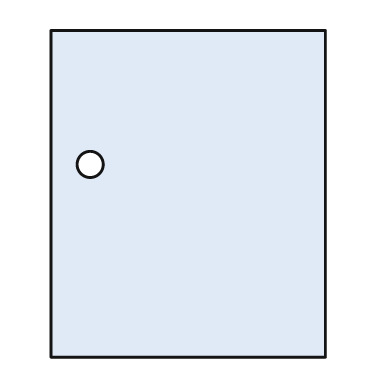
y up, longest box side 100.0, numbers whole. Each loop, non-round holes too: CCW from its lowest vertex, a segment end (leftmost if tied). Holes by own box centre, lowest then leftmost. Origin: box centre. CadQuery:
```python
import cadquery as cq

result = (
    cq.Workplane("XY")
    .moveTo(-42.0, -50.0)
    .lineTo(42.0, -50.0)
    .lineTo(42.0, 50.0)
    .lineTo(-42.0, 50.0)
    .close()
    .moveTo(-30.0, 9.0)
    .circle(4.0)
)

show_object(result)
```